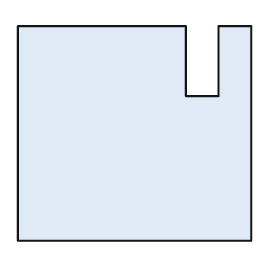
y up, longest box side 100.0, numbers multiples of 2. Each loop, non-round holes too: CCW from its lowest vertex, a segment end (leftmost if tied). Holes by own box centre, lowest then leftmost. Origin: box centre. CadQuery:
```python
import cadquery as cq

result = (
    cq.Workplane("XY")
    .moveTo(-50.0, -46.0)
    .lineTo(50.0, -46.0)
    .lineTo(50.0, 46.0)
    .lineTo(36.0, 46.0)
    .lineTo(36.0, 16.0)
    .lineTo(22.0, 16.0)
    .lineTo(22.0, 46.0)
    .lineTo(-50.0, 46.0)
    .close()
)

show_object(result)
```